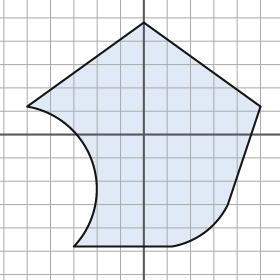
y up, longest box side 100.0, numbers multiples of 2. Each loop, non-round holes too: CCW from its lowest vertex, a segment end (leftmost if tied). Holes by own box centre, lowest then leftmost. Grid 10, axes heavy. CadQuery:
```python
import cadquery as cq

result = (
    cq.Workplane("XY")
    .moveTo(-30.0, -48.0)
    .lineTo(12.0, -48.0)
    .threePointArc((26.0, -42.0), (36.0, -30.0))
    .lineTo(50.0, 12.0)
    .lineTo(0.0, 48.0)
    .lineTo(-50.0, 12.0)
    .threePointArc((-22.0, -12.0), (-30.0, -48.0))
    .close()
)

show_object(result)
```